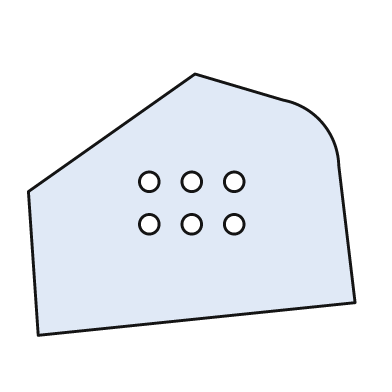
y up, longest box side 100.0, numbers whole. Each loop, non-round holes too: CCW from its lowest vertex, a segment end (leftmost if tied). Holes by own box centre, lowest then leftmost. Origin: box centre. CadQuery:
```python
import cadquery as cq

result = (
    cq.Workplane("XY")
    .moveTo(-47.0, -40.0)
    .lineTo(50.0, -30.0)
    .lineTo(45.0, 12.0)
    .threePointArc((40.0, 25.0), (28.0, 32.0))
    .lineTo(1.0, 40.0)
    .lineTo(-50.0, 4.0)
    .close()
    .moveTo(-13.0, -6.0)
    .circle(3.0)
    .moveTo(0.0, -6.0)
    .circle(3.0)
    .moveTo(13.0, -6.0)
    .circle(3.0)
    .moveTo(-13.0, 7.0)
    .circle(3.0)
    .moveTo(0.0, 7.0)
    .circle(3.0)
    .moveTo(13.0, 7.0)
    .circle(3.0)
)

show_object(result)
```